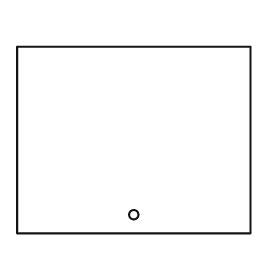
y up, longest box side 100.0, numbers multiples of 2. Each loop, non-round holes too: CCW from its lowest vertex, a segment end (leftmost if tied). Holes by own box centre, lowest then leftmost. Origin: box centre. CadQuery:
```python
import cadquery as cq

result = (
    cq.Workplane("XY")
    .moveTo(-50.0, -40.0)
    .lineTo(50.0, -40.0)
    .lineTo(50.0, 40.0)
    .lineTo(-50.0, 40.0)
    .close()
    .moveTo(0.0, -32.0)
    .circle(2.0)
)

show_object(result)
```